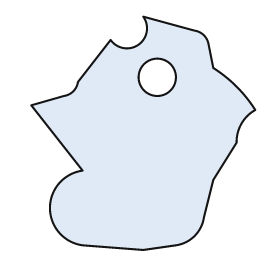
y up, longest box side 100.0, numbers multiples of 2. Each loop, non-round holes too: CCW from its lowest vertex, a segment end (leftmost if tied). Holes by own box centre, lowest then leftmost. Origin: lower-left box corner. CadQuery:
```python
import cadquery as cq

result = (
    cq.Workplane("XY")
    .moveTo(48.0, 0.0)
    .lineTo(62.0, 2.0)
    .threePointArc((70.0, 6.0), (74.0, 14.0))
    .lineTo(78.0, 30.0)
    .lineTo(88.0, 46.0)
    .threePointArc((90.0, 54.0), (96.0, 60.0))
    .threePointArc((88.0, 70.0), (78.0, 78.0))
    .lineTo(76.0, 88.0)
    .threePointArc((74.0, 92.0), (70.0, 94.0))
    .lineTo(48.0, 100.0)
    .threePointArc((46.0, 88.0), (34.0, 90.0))
    .lineTo(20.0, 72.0)
    .threePointArc((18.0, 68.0), (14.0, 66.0))
    .lineTo(0.0, 62.0)
    .lineTo(22.0, 34.0)
    .threePointArc((8.0, 18.0), (22.0, 2.0))
    .close()
    .moveTo(54.0, 74.0)
    .circle(8.0)
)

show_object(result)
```